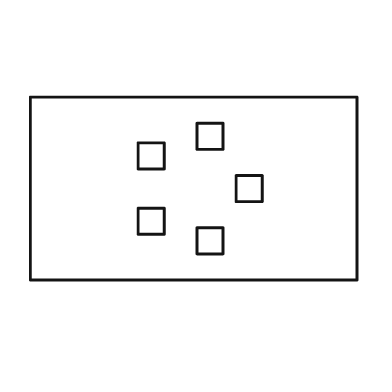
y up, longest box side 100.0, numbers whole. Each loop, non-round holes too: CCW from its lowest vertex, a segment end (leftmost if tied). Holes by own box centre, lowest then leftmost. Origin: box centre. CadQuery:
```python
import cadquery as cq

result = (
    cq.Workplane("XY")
    .moveTo(-50.0, -28.0)
    .lineTo(50.0, -28.0)
    .lineTo(50.0, 28.0)
    .lineTo(-50.0, 28.0)
    .close()
    .moveTo(1.0, -20.0)
    .lineTo(9.0, -20.0)
    .lineTo(9.0, -12.0)
    .lineTo(1.0, -12.0)
    .close()
    .moveTo(-17.0, -14.0)
    .lineTo(-9.0, -14.0)
    .lineTo(-9.0, -6.0)
    .lineTo(-17.0, -6.0)
    .close()
    .moveTo(13.0, -4.0)
    .lineTo(21.0, -4.0)
    .lineTo(21.0, 4.0)
    .lineTo(13.0, 4.0)
    .close()
    .moveTo(-17.0, 6.0)
    .lineTo(-9.0, 6.0)
    .lineTo(-9.0, 14.0)
    .lineTo(-17.0, 14.0)
    .close()
    .moveTo(1.0, 12.0)
    .lineTo(9.0, 12.0)
    .lineTo(9.0, 20.0)
    .lineTo(1.0, 20.0)
    .close()
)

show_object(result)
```